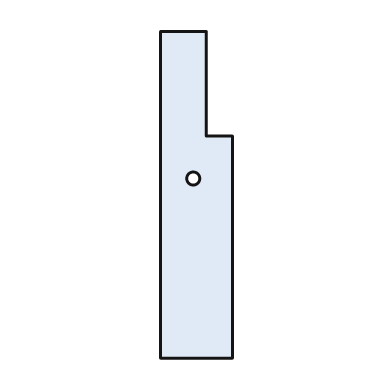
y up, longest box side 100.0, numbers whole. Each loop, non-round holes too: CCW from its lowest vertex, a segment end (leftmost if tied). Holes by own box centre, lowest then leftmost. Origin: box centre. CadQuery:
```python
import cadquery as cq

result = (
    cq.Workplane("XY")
    .moveTo(-11.0, -50.0)
    .lineTo(11.0, -50.0)
    .lineTo(11.0, 18.0)
    .lineTo(3.0, 18.0)
    .lineTo(3.0, 50.0)
    .lineTo(-11.0, 50.0)
    .close()
    .moveTo(-1.0, 5.0)
    .circle(2.0)
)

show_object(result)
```